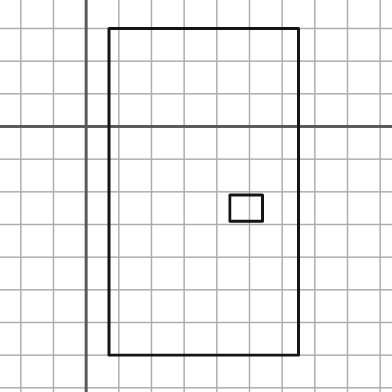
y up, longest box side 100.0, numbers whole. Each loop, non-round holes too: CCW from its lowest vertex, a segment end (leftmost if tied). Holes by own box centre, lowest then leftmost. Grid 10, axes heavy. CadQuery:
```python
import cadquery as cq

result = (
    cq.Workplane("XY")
    .moveTo(7.0, -70.0)
    .lineTo(65.0, -70.0)
    .lineTo(65.0, 30.0)
    .lineTo(7.0, 30.0)
    .close()
    .moveTo(44.0, -29.0)
    .lineTo(54.0, -29.0)
    .lineTo(54.0, -21.0)
    .lineTo(44.0, -21.0)
    .close()
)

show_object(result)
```